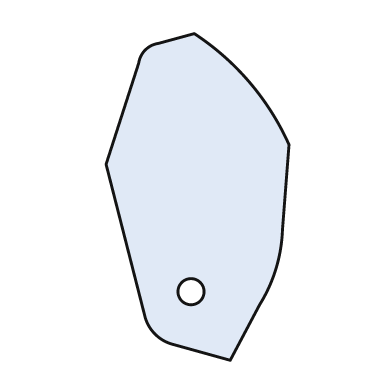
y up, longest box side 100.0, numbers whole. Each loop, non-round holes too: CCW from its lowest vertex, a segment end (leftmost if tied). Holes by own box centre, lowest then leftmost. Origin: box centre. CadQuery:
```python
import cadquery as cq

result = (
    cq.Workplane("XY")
    .moveTo(10.0, -50.0)
    .lineTo(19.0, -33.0)
    .threePointArc((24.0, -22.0), (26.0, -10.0))
    .lineTo(28.0, 16.0)
    .threePointArc((16.0, 35.0), (-1.0, 50.0))
    .lineTo(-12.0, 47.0)
    .threePointArc((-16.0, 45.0), (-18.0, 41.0))
    .lineTo(-28.0, 10.0)
    .lineTo(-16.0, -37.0)
    .threePointArc((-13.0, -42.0), (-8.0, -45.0))
    .close()
    .moveTo(-2.0, -29.0)
    .circle(4.0)
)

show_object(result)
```